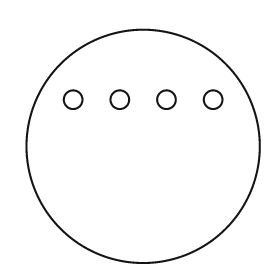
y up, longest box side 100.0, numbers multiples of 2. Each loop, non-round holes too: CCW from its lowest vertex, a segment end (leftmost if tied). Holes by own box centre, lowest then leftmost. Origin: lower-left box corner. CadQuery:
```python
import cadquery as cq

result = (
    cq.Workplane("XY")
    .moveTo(50.0, 50.0)
    .circle(50.0)
    .moveTo(20.0, 70.0)
    .circle(4.0)
    .moveTo(40.0, 70.0)
    .circle(4.0)
    .moveTo(60.0, 70.0)
    .circle(4.0)
    .moveTo(80.0, 70.0)
    .circle(4.0)
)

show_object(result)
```